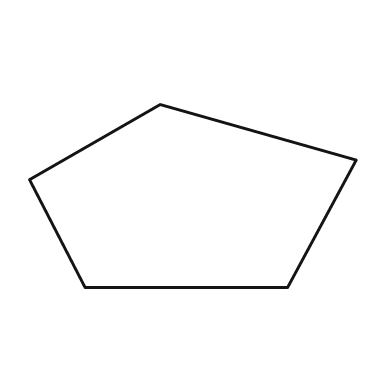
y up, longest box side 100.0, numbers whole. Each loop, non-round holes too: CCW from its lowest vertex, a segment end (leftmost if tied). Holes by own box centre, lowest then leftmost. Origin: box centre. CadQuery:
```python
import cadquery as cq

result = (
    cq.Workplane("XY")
    .moveTo(-33.0, -28.0)
    .lineTo(29.0, -28.0)
    .lineTo(50.0, 11.0)
    .lineTo(-10.0, 28.0)
    .lineTo(-50.0, 5.0)
    .close()
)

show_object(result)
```